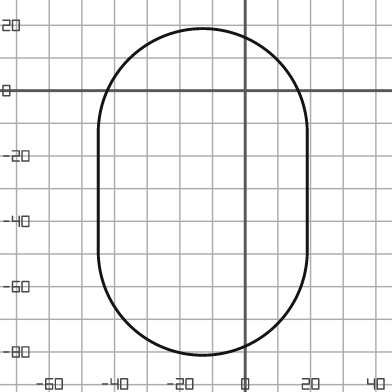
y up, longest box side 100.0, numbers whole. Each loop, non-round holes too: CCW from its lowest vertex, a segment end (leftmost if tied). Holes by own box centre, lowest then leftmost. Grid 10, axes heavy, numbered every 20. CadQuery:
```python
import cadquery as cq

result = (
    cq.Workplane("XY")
    .moveTo(-45.0, -49.0)
    .threePointArc((-13.0, -81.0), (19.0, -49.0))
    .lineTo(19.0, -13.0)
    .threePointArc((-13.0, 19.0), (-45.0, -13.0))
    .close()
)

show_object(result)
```